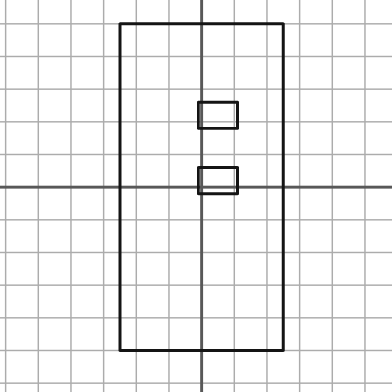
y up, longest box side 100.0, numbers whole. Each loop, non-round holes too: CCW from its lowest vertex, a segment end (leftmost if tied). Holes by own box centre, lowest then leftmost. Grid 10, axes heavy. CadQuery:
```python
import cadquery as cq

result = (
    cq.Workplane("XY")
    .moveTo(-25.0, -50.0)
    .lineTo(25.0, -50.0)
    .lineTo(25.0, 50.0)
    .lineTo(-25.0, 50.0)
    .close()
    .moveTo(-1.0, -2.0)
    .lineTo(11.0, -2.0)
    .lineTo(11.0, 6.0)
    .lineTo(-1.0, 6.0)
    .close()
    .moveTo(-1.0, 18.0)
    .lineTo(11.0, 18.0)
    .lineTo(11.0, 26.0)
    .lineTo(-1.0, 26.0)
    .close()
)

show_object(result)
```